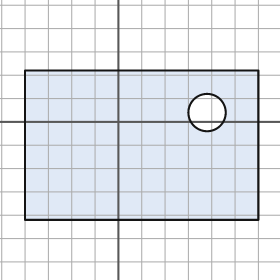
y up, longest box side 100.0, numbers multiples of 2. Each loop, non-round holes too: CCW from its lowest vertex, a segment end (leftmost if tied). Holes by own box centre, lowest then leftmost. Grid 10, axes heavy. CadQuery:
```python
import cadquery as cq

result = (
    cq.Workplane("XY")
    .moveTo(-40.0, -42.0)
    .lineTo(60.0, -42.0)
    .lineTo(60.0, 22.0)
    .lineTo(-40.0, 22.0)
    .close()
    .moveTo(38.0, 4.0)
    .circle(8.0)
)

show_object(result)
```